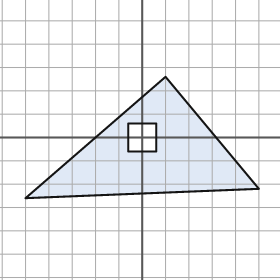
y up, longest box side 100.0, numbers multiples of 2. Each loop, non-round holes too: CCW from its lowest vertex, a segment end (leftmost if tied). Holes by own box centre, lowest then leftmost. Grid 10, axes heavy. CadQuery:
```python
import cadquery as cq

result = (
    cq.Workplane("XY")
    .moveTo(-50.0, -26.0)
    .lineTo(50.0, -22.0)
    .lineTo(10.0, 26.0)
    .close()
    .moveTo(-6.0, -6.0)
    .lineTo(6.0, -6.0)
    .lineTo(6.0, 6.0)
    .lineTo(-6.0, 6.0)
    .close()
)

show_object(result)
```